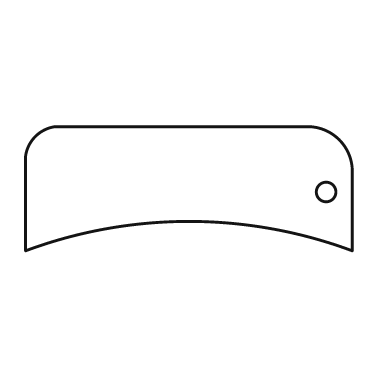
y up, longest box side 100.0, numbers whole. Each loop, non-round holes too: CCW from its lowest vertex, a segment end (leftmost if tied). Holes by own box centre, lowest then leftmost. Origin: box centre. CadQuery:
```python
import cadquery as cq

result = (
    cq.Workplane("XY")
    .moveTo(-50.0, -19.0)
    .threePointArc((0.0, -10.0), (50.0, -19.0))
    .lineTo(50.0, 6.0)
    .threePointArc((46.0, 15.0), (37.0, 19.0))
    .lineTo(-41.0, 19.0)
    .threePointArc((-47.0, 16.0), (-50.0, 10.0))
    .close()
    .moveTo(42.0, -1.0)
    .circle(3.0)
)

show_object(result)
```